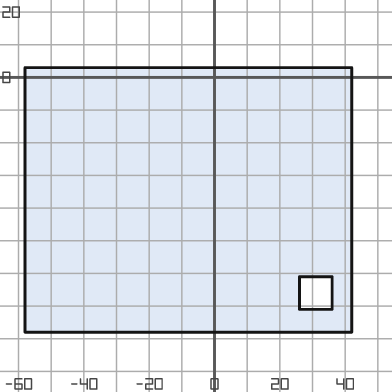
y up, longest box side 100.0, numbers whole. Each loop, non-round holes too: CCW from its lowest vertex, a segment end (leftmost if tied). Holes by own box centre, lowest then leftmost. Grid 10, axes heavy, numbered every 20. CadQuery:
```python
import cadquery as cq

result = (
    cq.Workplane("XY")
    .moveTo(-58.0, -78.0)
    .lineTo(42.0, -78.0)
    .lineTo(42.0, 3.0)
    .lineTo(-58.0, 3.0)
    .close()
    .moveTo(26.0, -71.0)
    .lineTo(36.0, -71.0)
    .lineTo(36.0, -61.0)
    .lineTo(26.0, -61.0)
    .close()
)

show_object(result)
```